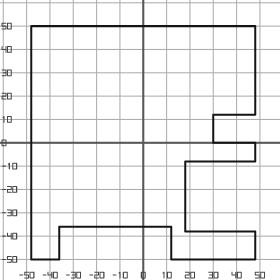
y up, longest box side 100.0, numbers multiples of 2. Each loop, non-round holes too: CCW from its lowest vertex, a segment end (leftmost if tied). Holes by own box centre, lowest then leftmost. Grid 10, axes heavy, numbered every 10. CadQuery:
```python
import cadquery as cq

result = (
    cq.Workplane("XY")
    .moveTo(-48.0, -50.0)
    .lineTo(-36.0, -50.0)
    .lineTo(-36.0, -36.0)
    .lineTo(12.0, -36.0)
    .lineTo(12.0, -50.0)
    .lineTo(48.0, -50.0)
    .lineTo(48.0, -38.0)
    .lineTo(18.0, -38.0)
    .lineTo(18.0, -8.0)
    .lineTo(48.0, -8.0)
    .lineTo(48.0, 0.0)
    .lineTo(30.0, 0.0)
    .lineTo(30.0, 12.0)
    .lineTo(48.0, 12.0)
    .lineTo(48.0, 50.0)
    .lineTo(-48.0, 50.0)
    .close()
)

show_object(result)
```